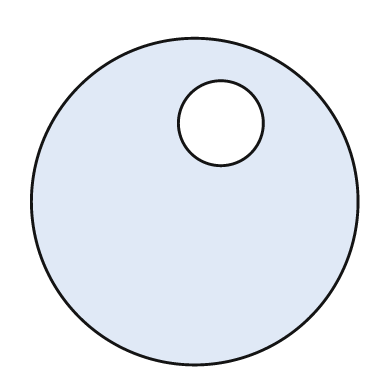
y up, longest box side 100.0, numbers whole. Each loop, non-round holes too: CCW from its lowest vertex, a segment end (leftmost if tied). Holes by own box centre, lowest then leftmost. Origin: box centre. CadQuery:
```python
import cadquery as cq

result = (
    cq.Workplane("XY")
    .moveTo(0.0, 0.0)
    .circle(50.0)
    .moveTo(8.0, 24.0)
    .circle(13.0)
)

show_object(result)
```